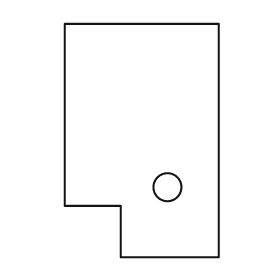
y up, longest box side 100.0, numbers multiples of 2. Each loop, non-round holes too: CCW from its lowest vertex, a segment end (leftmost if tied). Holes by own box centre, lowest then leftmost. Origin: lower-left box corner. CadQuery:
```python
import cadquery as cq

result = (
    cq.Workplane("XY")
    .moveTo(24.0, 0.0)
    .lineTo(66.0, 0.0)
    .lineTo(66.0, 100.0)
    .lineTo(0.0, 100.0)
    .lineTo(0.0, 22.0)
    .lineTo(24.0, 22.0)
    .close()
    .moveTo(44.0, 30.0)
    .circle(6.0)
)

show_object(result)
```